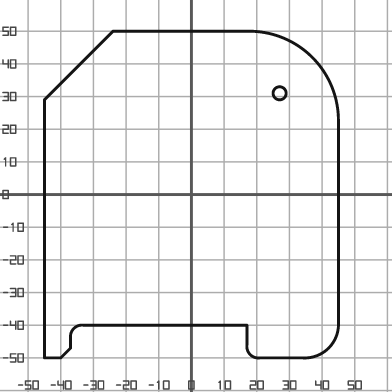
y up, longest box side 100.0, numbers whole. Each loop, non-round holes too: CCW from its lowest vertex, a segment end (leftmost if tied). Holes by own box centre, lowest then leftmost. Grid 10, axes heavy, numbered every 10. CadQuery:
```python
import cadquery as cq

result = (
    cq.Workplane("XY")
    .moveTo(-45.0, -50.0)
    .lineTo(-40.0, -50.0)
    .lineTo(-37.0, -47.0)
    .lineTo(-37.0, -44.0)
    .threePointArc((-36.0, -41.0), (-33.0, -40.0))
    .lineTo(17.0, -40.0)
    .lineTo(17.0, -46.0)
    .threePointArc((18.0, -49.0), (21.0, -50.0))
    .lineTo(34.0, -50.0)
    .threePointArc((42.0, -47.0), (45.0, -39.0))
    .lineTo(45.0, 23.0)
    .threePointArc((37.0, 42.0), (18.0, 50.0))
    .lineTo(-24.0, 50.0)
    .lineTo(-45.0, 29.0)
    .close()
    .moveTo(27.0, 31.0)
    .circle(2.0)
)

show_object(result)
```